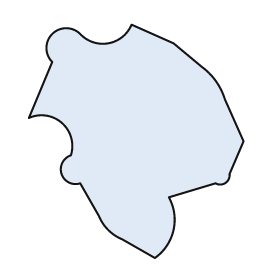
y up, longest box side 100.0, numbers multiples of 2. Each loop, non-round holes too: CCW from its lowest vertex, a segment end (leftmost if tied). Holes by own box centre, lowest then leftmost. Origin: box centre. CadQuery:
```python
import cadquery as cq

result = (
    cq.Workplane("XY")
    .moveTo(8.0, -50.0)
    .threePointArc((16.0, -38.0), (14.0, -24.0))
    .lineTo(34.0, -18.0)
    .threePointArc((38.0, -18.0), (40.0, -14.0))
    .lineTo(46.0, 0.0)
    .lineTo(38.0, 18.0)
    .threePointArc((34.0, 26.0), (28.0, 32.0))
    .lineTo(16.0, 42.0)
    .lineTo(-2.0, 50.0)
    .threePointArc((-12.0, 42.0), (-24.0, 46.0))
    .threePointArc((-36.0, 46.0), (-36.0, 34.0))
    .lineTo(-46.0, 10.0)
    .threePointArc((-32.0, 8.0), (-28.0, -6.0))
    .threePointArc((-32.0, -14.0), (-24.0, -18.0))
    .lineTo(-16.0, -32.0)
    .threePointArc((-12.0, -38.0), (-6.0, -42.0))
    .close()
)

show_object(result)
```